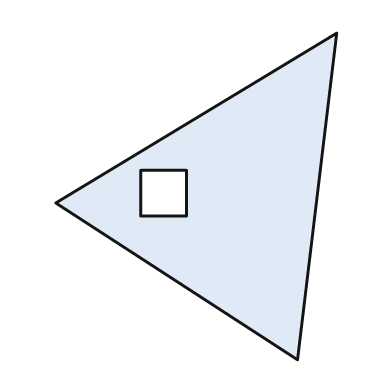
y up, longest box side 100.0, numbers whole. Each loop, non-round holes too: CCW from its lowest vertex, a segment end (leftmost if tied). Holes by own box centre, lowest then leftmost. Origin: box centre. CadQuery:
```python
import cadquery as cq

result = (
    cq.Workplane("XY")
    .moveTo(31.0, -50.0)
    .lineTo(43.0, 50.0)
    .lineTo(-43.0, -2.0)
    .close()
    .moveTo(-17.0, -6.0)
    .lineTo(-3.0, -6.0)
    .lineTo(-3.0, 8.0)
    .lineTo(-17.0, 8.0)
    .close()
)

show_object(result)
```